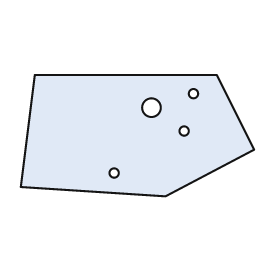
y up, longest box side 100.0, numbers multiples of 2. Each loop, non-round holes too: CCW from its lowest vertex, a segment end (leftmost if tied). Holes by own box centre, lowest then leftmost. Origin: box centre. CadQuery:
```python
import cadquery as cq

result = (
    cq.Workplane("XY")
    .moveTo(12.0, -26.0)
    .lineTo(50.0, -6.0)
    .lineTo(34.0, 26.0)
    .lineTo(-44.0, 26.0)
    .lineTo(-50.0, -22.0)
    .close()
    .moveTo(-10.0, -16.0)
    .circle(2.0)
    .moveTo(20.0, 2.0)
    .circle(2.0)
    .moveTo(6.0, 12.0)
    .circle(4.0)
    .moveTo(24.0, 18.0)
    .circle(2.0)
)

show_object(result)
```